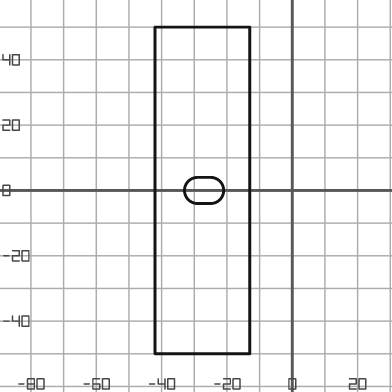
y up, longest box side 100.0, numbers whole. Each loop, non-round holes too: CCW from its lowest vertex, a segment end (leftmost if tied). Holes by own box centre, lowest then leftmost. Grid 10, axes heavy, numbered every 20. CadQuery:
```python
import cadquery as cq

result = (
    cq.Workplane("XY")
    .moveTo(-42.0, -50.0)
    .lineTo(-13.0, -50.0)
    .lineTo(-13.0, 50.0)
    .lineTo(-42.0, 50.0)
    .close()
    .moveTo(-29.0, -4.0)
    .lineTo(-25.0, -4.0)
    .threePointArc((-21.0, 0.0), (-25.0, 4.0))
    .lineTo(-29.0, 4.0)
    .threePointArc((-33.0, 0.0), (-29.0, -4.0))
    .close()
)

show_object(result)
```